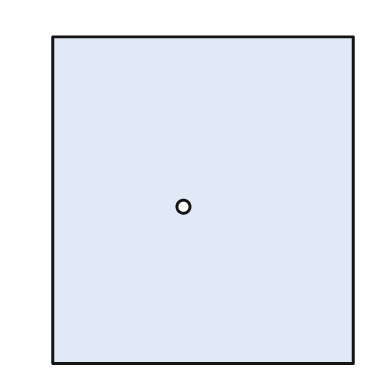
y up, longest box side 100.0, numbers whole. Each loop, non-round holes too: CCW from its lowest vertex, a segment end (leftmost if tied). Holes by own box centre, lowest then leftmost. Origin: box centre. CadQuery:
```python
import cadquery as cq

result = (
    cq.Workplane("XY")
    .moveTo(-46.0, -50.0)
    .lineTo(46.0, -50.0)
    .lineTo(46.0, 50.0)
    .lineTo(-46.0, 50.0)
    .close()
    .moveTo(-6.0, -2.0)
    .circle(2.0)
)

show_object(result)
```